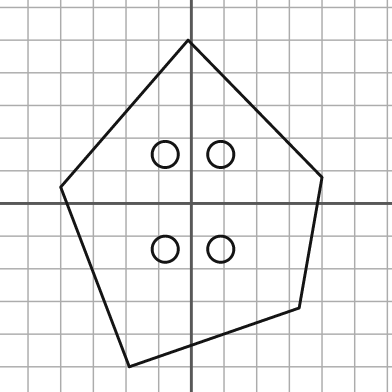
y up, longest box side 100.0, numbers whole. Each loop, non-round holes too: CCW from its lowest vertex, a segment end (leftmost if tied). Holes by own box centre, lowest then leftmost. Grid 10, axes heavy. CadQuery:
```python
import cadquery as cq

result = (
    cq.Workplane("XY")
    .moveTo(-19.0, -50.0)
    .lineTo(33.0, -32.0)
    .lineTo(40.0, 8.0)
    .lineTo(-1.0, 50.0)
    .lineTo(-40.0, 5.0)
    .close()
    .moveTo(-8.0, -14.0)
    .circle(4.0)
    .moveTo(9.0, -14.0)
    .circle(4.0)
    .moveTo(-8.0, 15.0)
    .circle(4.0)
    .moveTo(9.0, 15.0)
    .circle(4.0)
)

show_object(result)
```